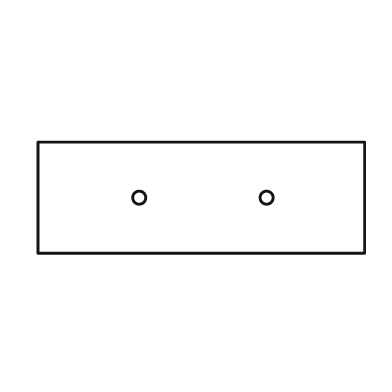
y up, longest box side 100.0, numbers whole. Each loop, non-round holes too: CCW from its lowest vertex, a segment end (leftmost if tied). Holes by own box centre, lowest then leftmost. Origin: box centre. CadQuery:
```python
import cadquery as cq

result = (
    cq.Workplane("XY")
    .moveTo(-50.0, -17.0)
    .lineTo(50.0, -17.0)
    .lineTo(50.0, 17.0)
    .lineTo(-50.0, 17.0)
    .close()
    .moveTo(-19.0, 0.0)
    .circle(2.0)
    .moveTo(20.0, 0.0)
    .circle(2.0)
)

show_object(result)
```